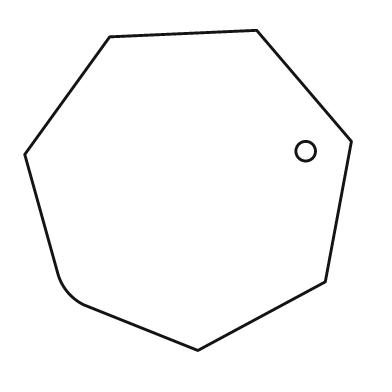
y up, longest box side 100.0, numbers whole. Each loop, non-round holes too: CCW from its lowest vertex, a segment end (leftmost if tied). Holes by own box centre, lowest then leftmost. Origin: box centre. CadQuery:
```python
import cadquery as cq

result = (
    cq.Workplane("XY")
    .moveTo(3.0, -49.0)
    .lineTo(42.0, -28.0)
    .lineTo(50.0, 15.0)
    .lineTo(21.0, 49.0)
    .lineTo(-24.0, 47.0)
    .lineTo(-50.0, 11.0)
    .lineTo(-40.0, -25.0)
    .threePointArc((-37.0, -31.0), (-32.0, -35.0))
    .close()
    .moveTo(36.0, 12.0)
    .circle(3.0)
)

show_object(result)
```